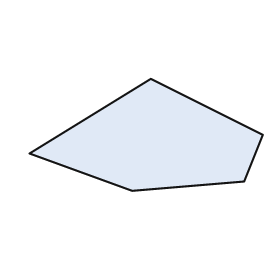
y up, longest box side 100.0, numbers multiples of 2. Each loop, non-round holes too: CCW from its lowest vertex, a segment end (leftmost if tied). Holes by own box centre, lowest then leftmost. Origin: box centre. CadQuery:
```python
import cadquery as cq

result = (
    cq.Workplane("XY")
    .moveTo(-6.0, -24.0)
    .lineTo(42.0, -20.0)
    .lineTo(50.0, 0.0)
    .lineTo(2.0, 24.0)
    .lineTo(-50.0, -8.0)
    .close()
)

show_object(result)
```